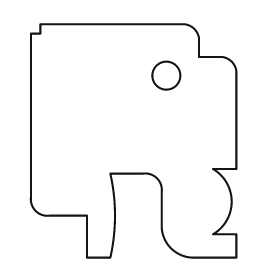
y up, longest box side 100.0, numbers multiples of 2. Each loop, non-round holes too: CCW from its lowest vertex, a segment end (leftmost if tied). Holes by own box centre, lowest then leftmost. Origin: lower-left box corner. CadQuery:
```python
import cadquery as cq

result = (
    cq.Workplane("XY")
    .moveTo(24.0, 0.0)
    .lineTo(34.0, 0.0)
    .threePointArc((36.0, 18.0), (34.0, 36.0))
    .lineTo(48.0, 36.0)
    .threePointArc((54.0, 34.0), (56.0, 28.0))
    .lineTo(56.0, 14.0)
    .threePointArc((60.0, 4.0), (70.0, 0.0))
    .lineTo(88.0, 0.0)
    .lineTo(88.0, 10.0)
    .lineTo(78.0, 10.0)
    .threePointArc((86.0, 24.0), (78.0, 38.0))
    .lineTo(88.0, 38.0)
    .lineTo(88.0, 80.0)
    .threePointArc((86.0, 84.0), (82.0, 86.0))
    .lineTo(72.0, 86.0)
    .lineTo(72.0, 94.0)
    .threePointArc((70.0, 98.0), (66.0, 100.0))
    .lineTo(4.0, 100.0)
    .lineTo(4.0, 96.0)
    .lineTo(0.0, 96.0)
    .lineTo(0.0, 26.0)
    .threePointArc((2.0, 20.0), (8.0, 18.0))
    .lineTo(24.0, 18.0)
    .close()
    .moveTo(58.0, 78.0)
    .circle(6.0)
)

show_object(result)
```